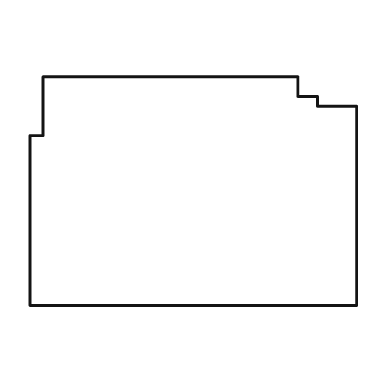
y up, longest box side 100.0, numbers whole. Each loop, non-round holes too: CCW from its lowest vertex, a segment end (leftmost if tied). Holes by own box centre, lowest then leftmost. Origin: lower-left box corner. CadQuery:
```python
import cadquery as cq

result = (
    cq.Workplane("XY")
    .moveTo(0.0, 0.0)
    .lineTo(100.0, 0.0)
    .lineTo(100.0, 61.0)
    .lineTo(88.0, 61.0)
    .lineTo(88.0, 64.0)
    .lineTo(82.0, 64.0)
    .lineTo(82.0, 70.0)
    .lineTo(4.0, 70.0)
    .lineTo(4.0, 52.0)
    .lineTo(0.0, 52.0)
    .close()
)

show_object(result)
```